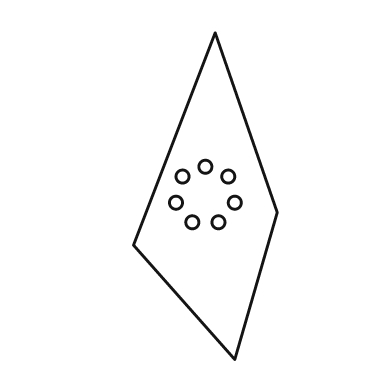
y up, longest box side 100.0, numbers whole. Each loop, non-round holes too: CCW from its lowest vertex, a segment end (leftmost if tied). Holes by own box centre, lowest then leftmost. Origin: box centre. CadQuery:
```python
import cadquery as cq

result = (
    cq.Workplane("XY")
    .moveTo(9.0, -50.0)
    .lineTo(22.0, -5.0)
    .lineTo(3.0, 50.0)
    .lineTo(-22.0, -15.0)
    .close()
    .moveTo(-4.0, -8.0)
    .circle(2.0)
    .moveTo(4.0, -8.0)
    .circle(2.0)
    .moveTo(-9.0, -2.0)
    .circle(2.0)
    .moveTo(9.0, -2.0)
    .circle(2.0)
    .moveTo(-7.0, 6.0)
    .circle(2.0)
    .moveTo(7.0, 6.0)
    .circle(2.0)
    .moveTo(0.0, 9.0)
    .circle(2.0)
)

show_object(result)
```